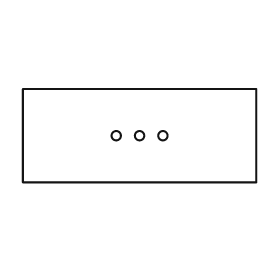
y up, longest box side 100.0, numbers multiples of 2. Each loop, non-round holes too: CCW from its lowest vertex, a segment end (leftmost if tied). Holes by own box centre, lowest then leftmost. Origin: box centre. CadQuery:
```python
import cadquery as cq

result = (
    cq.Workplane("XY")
    .moveTo(-50.0, -20.0)
    .lineTo(50.0, -20.0)
    .lineTo(50.0, 20.0)
    .lineTo(-50.0, 20.0)
    .close()
    .moveTo(-10.0, 0.0)
    .circle(2.0)
    .moveTo(0.0, 0.0)
    .circle(2.0)
    .moveTo(10.0, 0.0)
    .circle(2.0)
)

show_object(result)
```